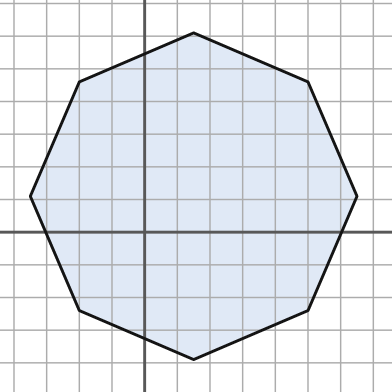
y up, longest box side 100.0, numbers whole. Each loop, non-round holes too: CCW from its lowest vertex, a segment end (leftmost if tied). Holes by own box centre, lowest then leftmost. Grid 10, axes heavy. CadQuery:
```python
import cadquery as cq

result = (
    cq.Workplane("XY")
    .moveTo(15.0, -39.0)
    .lineTo(50.0, -24.0)
    .lineTo(65.0, 11.0)
    .lineTo(50.0, 46.0)
    .lineTo(15.0, 61.0)
    .lineTo(-20.0, 46.0)
    .lineTo(-35.0, 11.0)
    .lineTo(-20.0, -24.0)
    .close()
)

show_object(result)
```